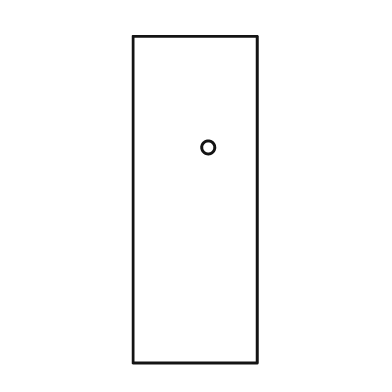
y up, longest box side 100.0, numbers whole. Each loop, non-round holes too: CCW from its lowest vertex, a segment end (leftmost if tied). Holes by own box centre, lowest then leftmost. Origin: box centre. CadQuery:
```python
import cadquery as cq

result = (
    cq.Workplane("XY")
    .moveTo(-19.0, -50.0)
    .lineTo(19.0, -50.0)
    .lineTo(19.0, 50.0)
    .lineTo(-19.0, 50.0)
    .close()
    .moveTo(4.0, 16.0)
    .circle(2.0)
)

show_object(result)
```